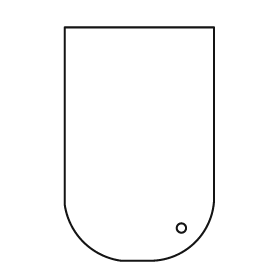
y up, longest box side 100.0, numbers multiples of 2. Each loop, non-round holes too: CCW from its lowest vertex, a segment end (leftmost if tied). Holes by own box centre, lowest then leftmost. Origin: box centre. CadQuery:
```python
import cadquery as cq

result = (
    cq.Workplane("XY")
    .moveTo(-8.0, -50.0)
    .lineTo(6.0, -50.0)
    .threePointArc((24.0, -42.0), (32.0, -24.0))
    .lineTo(32.0, 50.0)
    .lineTo(-32.0, 50.0)
    .lineTo(-32.0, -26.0)
    .threePointArc((-24.0, -42.0), (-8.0, -50.0))
    .close()
    .moveTo(18.0, -36.0)
    .circle(2.0)
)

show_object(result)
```